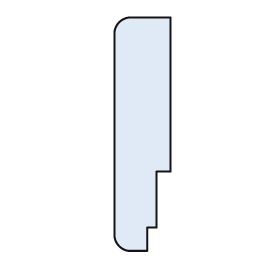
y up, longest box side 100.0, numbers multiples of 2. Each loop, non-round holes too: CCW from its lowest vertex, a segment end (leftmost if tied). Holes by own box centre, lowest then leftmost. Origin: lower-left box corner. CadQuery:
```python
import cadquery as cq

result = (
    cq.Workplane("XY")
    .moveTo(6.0, 0.0)
    .lineTo(14.0, 0.0)
    .lineTo(14.0, 10.0)
    .lineTo(18.0, 10.0)
    .lineTo(18.0, 34.0)
    .lineTo(24.0, 34.0)
    .lineTo(24.0, 100.0)
    .lineTo(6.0, 100.0)
    .threePointArc((2.0, 98.0), (0.0, 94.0))
    .lineTo(0.0, 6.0)
    .threePointArc((2.0, 2.0), (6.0, 0.0))
    .close()
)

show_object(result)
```